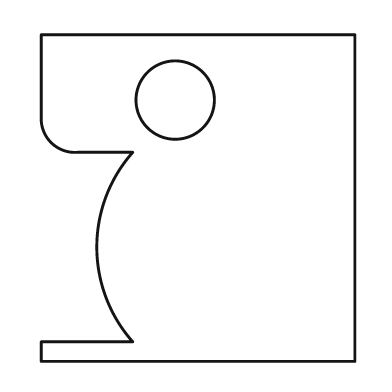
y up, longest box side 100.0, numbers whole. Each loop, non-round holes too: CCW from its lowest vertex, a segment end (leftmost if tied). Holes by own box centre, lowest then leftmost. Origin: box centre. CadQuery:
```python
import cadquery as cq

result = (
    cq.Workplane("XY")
    .moveTo(-48.0, -50.0)
    .lineTo(48.0, -50.0)
    .lineTo(48.0, 50.0)
    .lineTo(-48.0, 50.0)
    .lineTo(-48.0, 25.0)
    .threePointArc((-45.0, 17.0), (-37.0, 14.0))
    .lineTo(-20.0, 14.0)
    .threePointArc((-31.0, -15.0), (-20.0, -44.0))
    .lineTo(-48.0, -44.0)
    .close()
    .moveTo(-7.0, 30.0)
    .circle(12.0)
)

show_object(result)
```